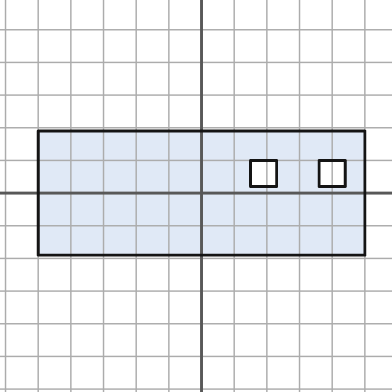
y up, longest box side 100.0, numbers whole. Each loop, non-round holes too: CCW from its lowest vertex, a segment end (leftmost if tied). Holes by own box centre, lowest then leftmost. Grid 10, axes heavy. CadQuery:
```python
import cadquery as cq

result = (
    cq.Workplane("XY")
    .moveTo(-50.0, -19.0)
    .lineTo(50.0, -19.0)
    .lineTo(50.0, 19.0)
    .lineTo(-50.0, 19.0)
    .close()
    .moveTo(15.0, 2.0)
    .lineTo(23.0, 2.0)
    .lineTo(23.0, 10.0)
    .lineTo(15.0, 10.0)
    .close()
    .moveTo(36.0, 2.0)
    .lineTo(44.0, 2.0)
    .lineTo(44.0, 10.0)
    .lineTo(36.0, 10.0)
    .close()
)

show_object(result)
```